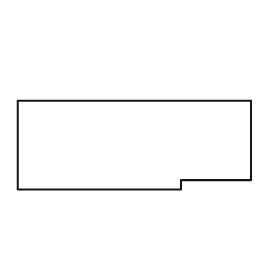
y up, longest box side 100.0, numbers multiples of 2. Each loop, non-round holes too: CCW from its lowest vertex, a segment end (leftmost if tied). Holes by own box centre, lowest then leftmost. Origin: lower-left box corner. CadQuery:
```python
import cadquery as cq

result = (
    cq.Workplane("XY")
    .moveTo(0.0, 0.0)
    .lineTo(70.0, 0.0)
    .lineTo(70.0, 4.0)
    .lineTo(100.0, 4.0)
    .lineTo(100.0, 38.0)
    .lineTo(0.0, 38.0)
    .close()
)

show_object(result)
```